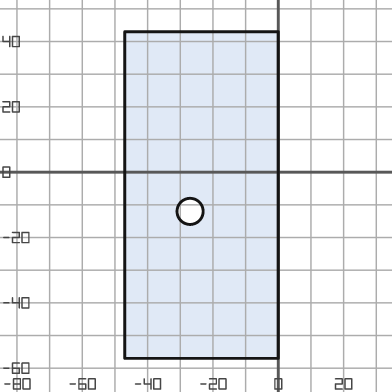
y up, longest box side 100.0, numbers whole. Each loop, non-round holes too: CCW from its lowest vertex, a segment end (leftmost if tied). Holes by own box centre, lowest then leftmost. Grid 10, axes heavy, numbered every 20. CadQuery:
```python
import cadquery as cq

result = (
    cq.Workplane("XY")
    .moveTo(-47.0, -57.0)
    .lineTo(0.0, -57.0)
    .lineTo(0.0, 43.0)
    .lineTo(-47.0, 43.0)
    .close()
    .moveTo(-27.0, -12.0)
    .circle(4.0)
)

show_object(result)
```